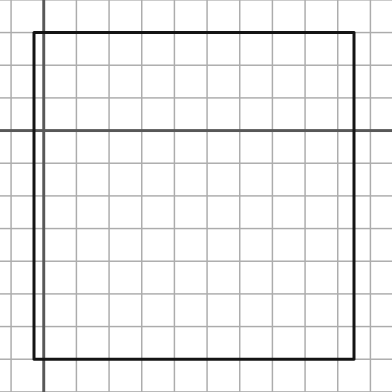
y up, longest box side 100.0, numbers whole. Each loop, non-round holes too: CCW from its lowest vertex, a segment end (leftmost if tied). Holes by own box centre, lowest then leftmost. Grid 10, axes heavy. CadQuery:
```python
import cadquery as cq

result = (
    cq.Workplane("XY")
    .moveTo(-3.0, -70.0)
    .lineTo(95.0, -70.0)
    .lineTo(95.0, 30.0)
    .lineTo(-3.0, 30.0)
    .close()
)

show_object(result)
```